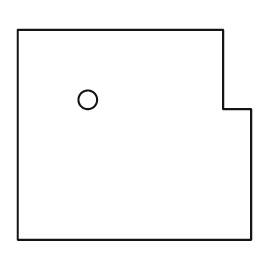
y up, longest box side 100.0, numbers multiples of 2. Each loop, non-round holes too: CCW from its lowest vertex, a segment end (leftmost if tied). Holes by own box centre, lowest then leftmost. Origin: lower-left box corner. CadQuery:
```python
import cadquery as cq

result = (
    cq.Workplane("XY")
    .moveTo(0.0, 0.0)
    .lineTo(100.0, 0.0)
    .lineTo(100.0, 56.0)
    .lineTo(88.0, 56.0)
    .lineTo(88.0, 90.0)
    .lineTo(0.0, 90.0)
    .close()
    .moveTo(30.0, 60.0)
    .circle(4.0)
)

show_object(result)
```